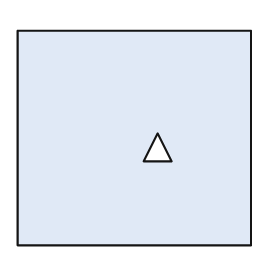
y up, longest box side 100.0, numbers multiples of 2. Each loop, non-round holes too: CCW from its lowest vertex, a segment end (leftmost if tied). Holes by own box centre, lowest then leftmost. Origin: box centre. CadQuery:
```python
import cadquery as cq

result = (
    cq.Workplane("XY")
    .moveTo(-50.0, -46.0)
    .lineTo(50.0, -46.0)
    .lineTo(50.0, 46.0)
    .lineTo(-50.0, 46.0)
    .close()
    .moveTo(4.0, -10.0)
    .lineTo(16.0, -10.0)
    .lineTo(10.0, 2.0)
    .close()
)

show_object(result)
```